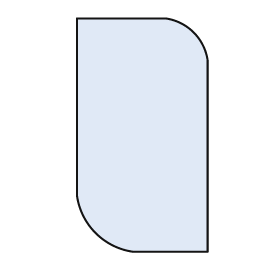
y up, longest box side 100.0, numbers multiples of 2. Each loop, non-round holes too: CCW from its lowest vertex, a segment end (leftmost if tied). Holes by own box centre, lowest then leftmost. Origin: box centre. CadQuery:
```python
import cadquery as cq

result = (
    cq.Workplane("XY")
    .moveTo(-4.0, -50.0)
    .lineTo(28.0, -50.0)
    .lineTo(28.0, 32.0)
    .threePointArc((22.0, 44.0), (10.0, 50.0))
    .lineTo(-28.0, 50.0)
    .lineTo(-28.0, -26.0)
    .threePointArc((-20.0, -42.0), (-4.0, -50.0))
    .close()
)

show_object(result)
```